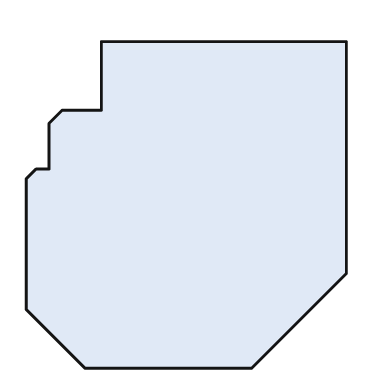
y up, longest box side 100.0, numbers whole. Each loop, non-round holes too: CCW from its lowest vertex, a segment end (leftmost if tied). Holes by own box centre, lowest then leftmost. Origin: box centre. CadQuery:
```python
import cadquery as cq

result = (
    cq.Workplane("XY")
    .moveTo(-31.0, -50.0)
    .lineTo(20.0, -50.0)
    .lineTo(49.0, -21.0)
    .lineTo(49.0, 50.0)
    .lineTo(-26.0, 50.0)
    .lineTo(-26.0, 29.0)
    .lineTo(-38.0, 29.0)
    .lineTo(-42.0, 25.0)
    .lineTo(-42.0, 11.0)
    .lineTo(-46.0, 11.0)
    .lineTo(-49.0, 8.0)
    .lineTo(-49.0, -32.0)
    .close()
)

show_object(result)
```